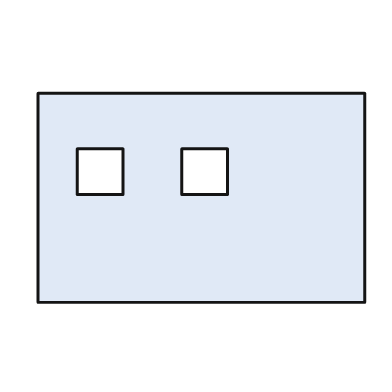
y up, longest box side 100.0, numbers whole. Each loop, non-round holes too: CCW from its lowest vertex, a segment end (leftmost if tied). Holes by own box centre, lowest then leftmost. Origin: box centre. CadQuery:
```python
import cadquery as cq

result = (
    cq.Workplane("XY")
    .moveTo(-50.0, -32.0)
    .lineTo(50.0, -32.0)
    .lineTo(50.0, 32.0)
    .lineTo(-50.0, 32.0)
    .close()
    .moveTo(-38.0, 1.0)
    .lineTo(-24.0, 1.0)
    .lineTo(-24.0, 15.0)
    .lineTo(-38.0, 15.0)
    .close()
    .moveTo(-6.0, 1.0)
    .lineTo(8.0, 1.0)
    .lineTo(8.0, 15.0)
    .lineTo(-6.0, 15.0)
    .close()
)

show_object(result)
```